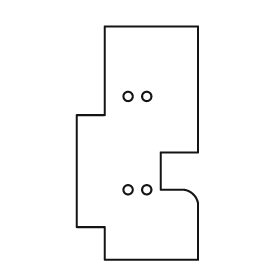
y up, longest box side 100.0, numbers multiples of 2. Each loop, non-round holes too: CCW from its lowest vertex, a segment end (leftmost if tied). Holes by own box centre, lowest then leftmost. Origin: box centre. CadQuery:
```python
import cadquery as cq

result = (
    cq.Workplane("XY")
    .moveTo(-14.0, -50.0)
    .lineTo(26.0, -50.0)
    .lineTo(26.0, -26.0)
    .threePointArc((24.0, -22.0), (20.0, -20.0))
    .lineTo(10.0, -20.0)
    .lineTo(10.0, -4.0)
    .lineTo(26.0, -4.0)
    .lineTo(26.0, 50.0)
    .lineTo(-14.0, 50.0)
    .lineTo(-14.0, 12.0)
    .lineTo(-26.0, 12.0)
    .lineTo(-26.0, -36.0)
    .lineTo(-14.0, -36.0)
    .close()
    .moveTo(-4.0, -20.0)
    .circle(2.0)
    .moveTo(4.0, -20.0)
    .circle(2.0)
    .moveTo(-4.0, 20.0)
    .circle(2.0)
    .moveTo(4.0, 20.0)
    .circle(2.0)
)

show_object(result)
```